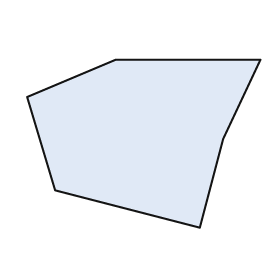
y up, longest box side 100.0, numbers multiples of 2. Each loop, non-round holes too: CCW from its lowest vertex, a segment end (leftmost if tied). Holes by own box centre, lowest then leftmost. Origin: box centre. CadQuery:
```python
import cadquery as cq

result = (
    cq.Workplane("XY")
    .moveTo(24.0, -36.0)
    .lineTo(34.0, 2.0)
    .lineTo(50.0, 36.0)
    .lineTo(-12.0, 36.0)
    .lineTo(-50.0, 20.0)
    .lineTo(-38.0, -20.0)
    .close()
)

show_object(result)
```